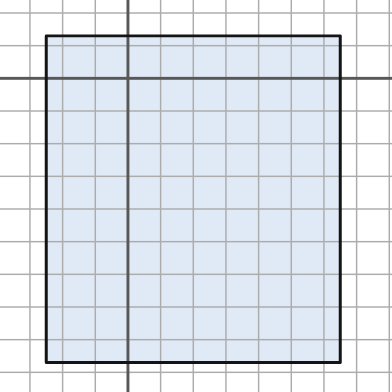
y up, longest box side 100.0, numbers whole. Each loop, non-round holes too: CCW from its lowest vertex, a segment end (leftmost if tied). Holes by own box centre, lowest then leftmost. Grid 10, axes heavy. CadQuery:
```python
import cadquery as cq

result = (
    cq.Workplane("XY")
    .moveTo(-25.0, -87.0)
    .lineTo(65.0, -87.0)
    .lineTo(65.0, 13.0)
    .lineTo(-25.0, 13.0)
    .close()
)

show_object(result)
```